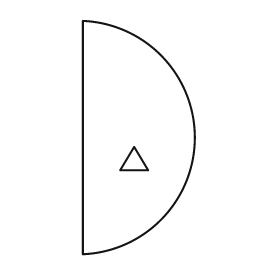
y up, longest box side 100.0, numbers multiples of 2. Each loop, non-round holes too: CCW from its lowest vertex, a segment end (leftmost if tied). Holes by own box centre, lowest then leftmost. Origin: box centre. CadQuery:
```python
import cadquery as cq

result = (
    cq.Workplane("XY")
    .moveTo(-24.0, -50.0)
    .threePointArc((24.0, 0.0), (-24.0, 50.0))
    .close()
    .moveTo(-8.0, -14.0)
    .lineTo(4.0, -14.0)
    .lineTo(-2.0, -4.0)
    .close()
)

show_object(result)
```